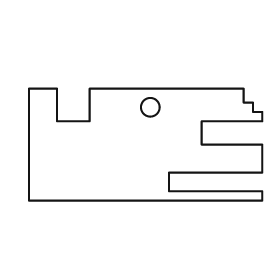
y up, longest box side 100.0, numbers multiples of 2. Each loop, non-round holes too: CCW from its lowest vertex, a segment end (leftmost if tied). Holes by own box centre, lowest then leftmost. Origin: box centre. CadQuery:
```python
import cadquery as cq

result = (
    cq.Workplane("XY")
    .moveTo(-50.0, -24.0)
    .lineTo(50.0, -24.0)
    .lineTo(50.0, -20.0)
    .lineTo(10.0, -20.0)
    .lineTo(10.0, -12.0)
    .lineTo(50.0, -12.0)
    .lineTo(50.0, 0.0)
    .lineTo(24.0, 0.0)
    .lineTo(24.0, 10.0)
    .lineTo(50.0, 10.0)
    .lineTo(50.0, 14.0)
    .lineTo(46.0, 14.0)
    .lineTo(46.0, 18.0)
    .lineTo(42.0, 18.0)
    .lineTo(42.0, 24.0)
    .lineTo(-24.0, 24.0)
    .lineTo(-24.0, 10.0)
    .lineTo(-38.0, 10.0)
    .lineTo(-38.0, 24.0)
    .lineTo(-50.0, 24.0)
    .close()
    .moveTo(2.0, 16.0)
    .circle(4.0)
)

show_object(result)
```